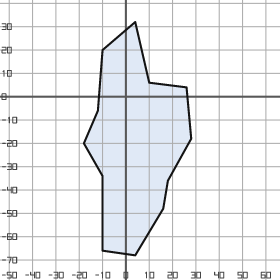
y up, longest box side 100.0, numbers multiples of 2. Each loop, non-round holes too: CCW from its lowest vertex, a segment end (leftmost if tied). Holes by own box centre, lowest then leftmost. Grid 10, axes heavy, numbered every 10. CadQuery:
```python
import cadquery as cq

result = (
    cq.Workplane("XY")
    .moveTo(4.0, -68.0)
    .lineTo(16.0, -48.0)
    .lineTo(18.0, -36.0)
    .lineTo(28.0, -18.0)
    .lineTo(26.0, 4.0)
    .lineTo(10.0, 6.0)
    .lineTo(4.0, 32.0)
    .lineTo(-10.0, 20.0)
    .lineTo(-12.0, -6.0)
    .lineTo(-18.0, -20.0)
    .lineTo(-10.0, -34.0)
    .lineTo(-10.0, -66.0)
    .close()
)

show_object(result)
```